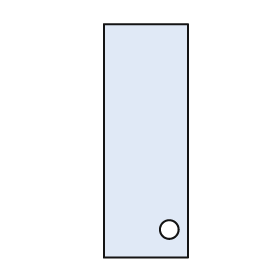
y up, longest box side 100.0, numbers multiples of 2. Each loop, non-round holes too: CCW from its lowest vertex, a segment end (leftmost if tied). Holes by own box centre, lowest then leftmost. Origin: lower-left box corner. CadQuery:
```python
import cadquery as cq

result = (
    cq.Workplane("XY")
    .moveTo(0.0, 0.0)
    .lineTo(36.0, 0.0)
    .lineTo(36.0, 100.0)
    .lineTo(0.0, 100.0)
    .close()
    .moveTo(28.0, 12.0)
    .circle(4.0)
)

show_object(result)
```